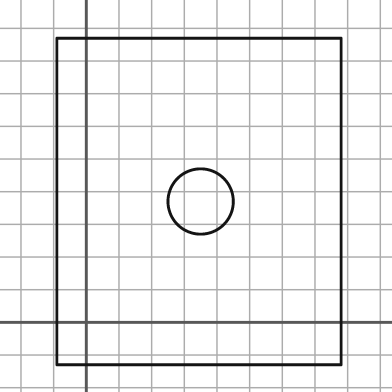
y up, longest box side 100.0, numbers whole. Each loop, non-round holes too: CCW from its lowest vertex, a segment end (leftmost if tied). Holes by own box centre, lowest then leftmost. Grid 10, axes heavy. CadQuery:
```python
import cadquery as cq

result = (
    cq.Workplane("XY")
    .moveTo(-9.0, -13.0)
    .lineTo(78.0, -13.0)
    .lineTo(78.0, 87.0)
    .lineTo(-9.0, 87.0)
    .close()
    .moveTo(35.0, 37.0)
    .circle(10.0)
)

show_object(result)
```